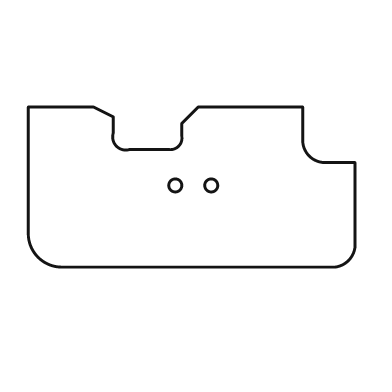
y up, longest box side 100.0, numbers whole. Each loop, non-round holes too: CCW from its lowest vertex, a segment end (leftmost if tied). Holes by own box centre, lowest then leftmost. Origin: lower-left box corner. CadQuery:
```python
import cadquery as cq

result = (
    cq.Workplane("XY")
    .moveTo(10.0, 0.0)
    .lineTo(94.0, 0.0)
    .threePointArc((98.0, 2.0), (100.0, 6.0))
    .lineTo(100.0, 32.0)
    .lineTo(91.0, 32.0)
    .threePointArc((86.0, 34.0), (84.0, 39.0))
    .lineTo(84.0, 49.0)
    .lineTo(52.0, 49.0)
    .lineTo(47.0, 44.0)
    .lineTo(47.0, 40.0)
    .threePointArc((46.0, 37.0), (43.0, 36.0))
    .lineTo(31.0, 36.0)
    .threePointArc((27.0, 37.0), (26.0, 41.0))
    .lineTo(26.0, 46.0)
    .lineTo(20.0, 49.0)
    .lineTo(0.0, 49.0)
    .lineTo(0.0, 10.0)
    .threePointArc((3.0, 3.0), (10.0, 0.0))
    .close()
    .moveTo(45.0, 25.0)
    .circle(2.0)
    .moveTo(56.0, 25.0)
    .circle(2.0)
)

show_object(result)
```